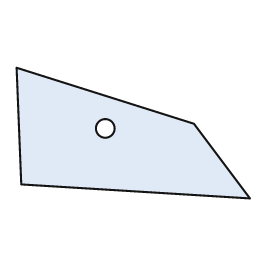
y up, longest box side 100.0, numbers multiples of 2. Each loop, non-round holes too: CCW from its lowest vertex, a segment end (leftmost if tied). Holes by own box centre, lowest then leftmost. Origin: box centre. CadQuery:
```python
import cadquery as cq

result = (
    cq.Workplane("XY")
    .moveTo(50.0, -28.0)
    .lineTo(26.0, 4.0)
    .lineTo(-50.0, 28.0)
    .lineTo(-48.0, -22.0)
    .close()
    .moveTo(-12.0, 2.0)
    .circle(4.0)
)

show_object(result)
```